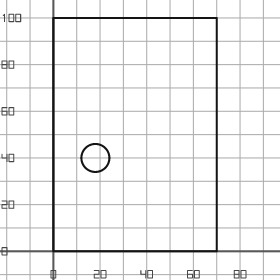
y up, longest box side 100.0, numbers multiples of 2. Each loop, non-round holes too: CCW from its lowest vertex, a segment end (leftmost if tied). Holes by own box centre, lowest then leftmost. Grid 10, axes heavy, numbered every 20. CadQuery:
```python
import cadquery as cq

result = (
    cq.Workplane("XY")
    .moveTo(0.0, 0.0)
    .lineTo(70.0, 0.0)
    .lineTo(70.0, 100.0)
    .lineTo(0.0, 100.0)
    .close()
    .moveTo(18.0, 40.0)
    .circle(6.0)
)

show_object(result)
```